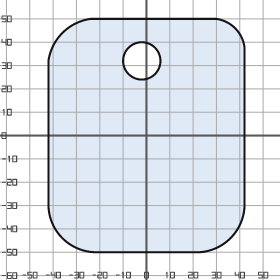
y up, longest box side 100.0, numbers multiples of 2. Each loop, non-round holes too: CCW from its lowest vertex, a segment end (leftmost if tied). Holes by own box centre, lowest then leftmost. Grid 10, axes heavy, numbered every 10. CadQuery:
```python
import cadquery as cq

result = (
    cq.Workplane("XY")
    .moveTo(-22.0, -50.0)
    .lineTo(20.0, -50.0)
    .threePointArc((36.0, -44.0), (42.0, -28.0))
    .lineTo(42.0, 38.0)
    .threePointArc((38.0, 46.0), (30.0, 50.0))
    .lineTo(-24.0, 50.0)
    .threePointArc((-36.0, 44.0), (-42.0, 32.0))
    .lineTo(-42.0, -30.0)
    .threePointArc((-36.0, -44.0), (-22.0, -50.0))
    .close()
    .moveTo(-2.0, 32.0)
    .circle(8.0)
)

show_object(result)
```